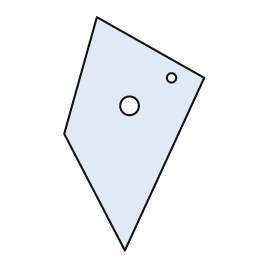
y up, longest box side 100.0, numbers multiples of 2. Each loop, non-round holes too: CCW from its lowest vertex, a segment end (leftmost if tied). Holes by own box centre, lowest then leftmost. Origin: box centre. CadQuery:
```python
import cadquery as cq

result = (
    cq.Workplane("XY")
    .moveTo(-4.0, -50.0)
    .lineTo(30.0, 24.0)
    .lineTo(-16.0, 50.0)
    .lineTo(-30.0, 0.0)
    .close()
    .moveTo(-2.0, 12.0)
    .circle(4.0)
    .moveTo(16.0, 24.0)
    .circle(2.0)
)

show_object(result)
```